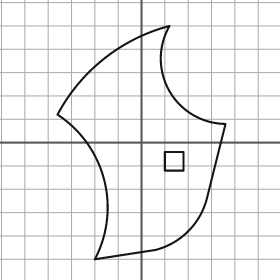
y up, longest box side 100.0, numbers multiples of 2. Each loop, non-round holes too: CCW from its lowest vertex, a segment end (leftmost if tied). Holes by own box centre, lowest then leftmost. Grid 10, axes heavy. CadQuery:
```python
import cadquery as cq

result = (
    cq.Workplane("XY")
    .moveTo(-20.0, -50.0)
    .lineTo(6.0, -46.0)
    .threePointArc((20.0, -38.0), (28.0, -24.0))
    .lineTo(36.0, 8.0)
    .threePointArc((12.0, 22.0), (12.0, 50.0))
    .threePointArc((-16.0, 36.0), (-36.0, 12.0))
    .threePointArc((-16.0, -16.0), (-20.0, -50.0))
    .close()
    .moveTo(10.0, -12.0)
    .lineTo(18.0, -12.0)
    .lineTo(18.0, -4.0)
    .lineTo(10.0, -4.0)
    .close()
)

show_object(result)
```